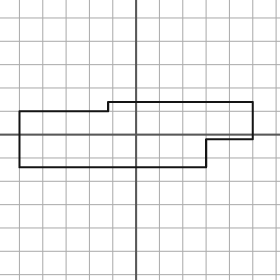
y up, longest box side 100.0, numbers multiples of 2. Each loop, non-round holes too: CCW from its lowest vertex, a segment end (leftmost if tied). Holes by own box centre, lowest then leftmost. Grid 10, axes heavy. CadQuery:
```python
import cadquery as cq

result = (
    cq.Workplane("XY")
    .moveTo(-50.0, -14.0)
    .lineTo(30.0, -14.0)
    .lineTo(30.0, -2.0)
    .lineTo(50.0, -2.0)
    .lineTo(50.0, 14.0)
    .lineTo(-12.0, 14.0)
    .lineTo(-12.0, 10.0)
    .lineTo(-50.0, 10.0)
    .close()
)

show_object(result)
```